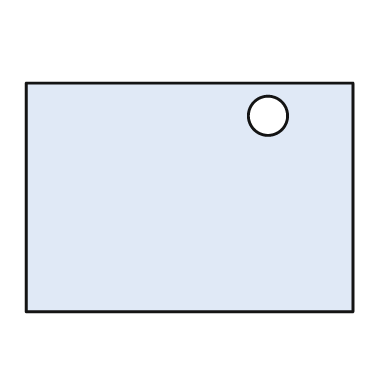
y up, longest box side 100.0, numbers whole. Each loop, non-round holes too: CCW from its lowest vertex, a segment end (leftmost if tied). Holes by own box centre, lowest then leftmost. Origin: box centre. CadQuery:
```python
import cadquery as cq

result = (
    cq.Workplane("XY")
    .moveTo(-50.0, -35.0)
    .lineTo(50.0, -35.0)
    .lineTo(50.0, 35.0)
    .lineTo(-50.0, 35.0)
    .close()
    .moveTo(24.0, 25.0)
    .circle(6.0)
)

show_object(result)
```